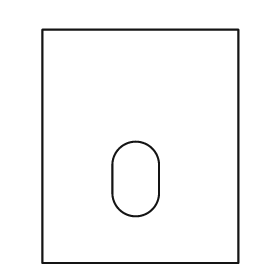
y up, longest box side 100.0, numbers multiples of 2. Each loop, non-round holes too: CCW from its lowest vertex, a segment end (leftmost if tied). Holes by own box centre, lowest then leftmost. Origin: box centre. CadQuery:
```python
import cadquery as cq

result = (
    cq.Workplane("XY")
    .moveTo(-42.0, -50.0)
    .lineTo(42.0, -50.0)
    .lineTo(42.0, 50.0)
    .lineTo(-42.0, 50.0)
    .close()
    .moveTo(-12.0, -20.0)
    .threePointArc((-2.0, -30.0), (8.0, -20.0))
    .lineTo(8.0, -8.0)
    .threePointArc((-2.0, 2.0), (-12.0, -8.0))
    .close()
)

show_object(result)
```